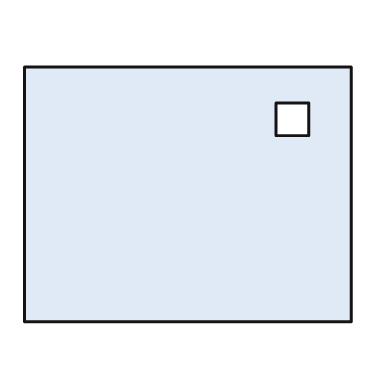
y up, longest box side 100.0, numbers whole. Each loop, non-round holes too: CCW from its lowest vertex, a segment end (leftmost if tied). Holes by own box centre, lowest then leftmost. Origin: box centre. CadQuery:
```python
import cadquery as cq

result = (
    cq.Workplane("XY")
    .moveTo(-50.0, -39.0)
    .lineTo(50.0, -39.0)
    .lineTo(50.0, 39.0)
    .lineTo(-50.0, 39.0)
    .close()
    .moveTo(27.0, 18.0)
    .lineTo(37.0, 18.0)
    .lineTo(37.0, 28.0)
    .lineTo(27.0, 28.0)
    .close()
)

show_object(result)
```